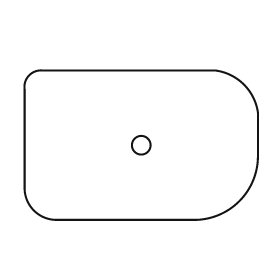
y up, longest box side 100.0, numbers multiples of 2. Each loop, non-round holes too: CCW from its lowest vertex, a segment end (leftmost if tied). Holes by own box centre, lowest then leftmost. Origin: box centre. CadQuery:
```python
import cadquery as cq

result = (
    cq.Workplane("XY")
    .moveTo(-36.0, -32.0)
    .lineTo(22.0, -32.0)
    .threePointArc((42.0, -24.0), (50.0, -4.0))
    .lineTo(50.0, 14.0)
    .threePointArc((44.0, 26.0), (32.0, 32.0))
    .lineTo(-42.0, 32.0)
    .threePointArc((-48.0, 30.0), (-50.0, 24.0))
    .lineTo(-50.0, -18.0)
    .threePointArc((-46.0, -28.0), (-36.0, -32.0))
    .close()
    .moveTo(0.0, 0.0)
    .circle(4.0)
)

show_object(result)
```